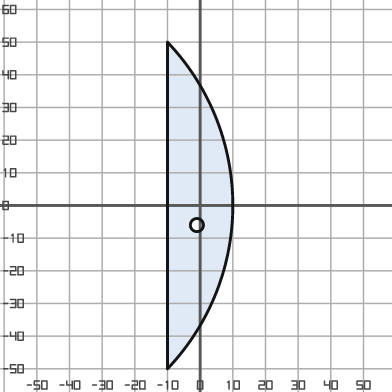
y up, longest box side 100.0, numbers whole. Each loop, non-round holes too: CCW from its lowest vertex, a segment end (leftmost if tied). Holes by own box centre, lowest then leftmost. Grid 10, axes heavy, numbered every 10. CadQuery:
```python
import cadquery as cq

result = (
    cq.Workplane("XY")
    .moveTo(-10.0, -50.0)
    .threePointArc((10.0, 0.0), (-10.0, 50.0))
    .close()
    .moveTo(-1.0, -6.0)
    .circle(2.0)
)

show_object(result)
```